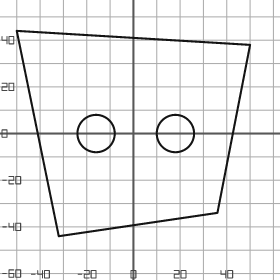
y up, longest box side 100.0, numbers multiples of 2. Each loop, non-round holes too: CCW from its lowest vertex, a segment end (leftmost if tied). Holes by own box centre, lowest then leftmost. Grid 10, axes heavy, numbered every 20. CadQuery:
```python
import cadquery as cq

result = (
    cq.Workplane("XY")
    .moveTo(-32.0, -44.0)
    .lineTo(36.0, -34.0)
    .lineTo(50.0, 38.0)
    .lineTo(-50.0, 44.0)
    .close()
    .moveTo(-16.0, 0.0)
    .circle(8.0)
    .moveTo(18.0, 0.0)
    .circle(8.0)
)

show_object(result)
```